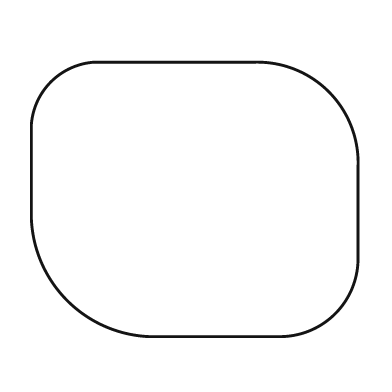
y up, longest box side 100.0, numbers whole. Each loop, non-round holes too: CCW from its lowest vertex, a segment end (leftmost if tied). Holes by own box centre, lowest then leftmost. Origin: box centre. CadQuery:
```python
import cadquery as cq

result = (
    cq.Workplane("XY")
    .moveTo(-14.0, -42.0)
    .lineTo(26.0, -42.0)
    .threePointArc((43.0, -35.0), (50.0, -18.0))
    .lineTo(50.0, 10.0)
    .threePointArc((41.0, 33.0), (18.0, 42.0))
    .lineTo(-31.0, 42.0)
    .threePointArc((-44.0, 36.0), (-50.0, 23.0))
    .lineTo(-50.0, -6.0)
    .threePointArc((-39.0, -31.0), (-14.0, -42.0))
    .close()
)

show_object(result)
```